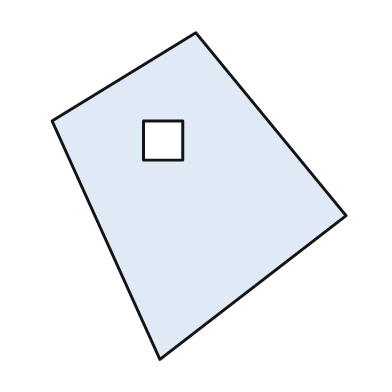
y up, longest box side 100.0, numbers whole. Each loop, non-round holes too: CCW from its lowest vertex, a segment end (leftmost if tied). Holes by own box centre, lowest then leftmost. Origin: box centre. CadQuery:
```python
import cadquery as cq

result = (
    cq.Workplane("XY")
    .moveTo(-12.0, -50.0)
    .lineTo(45.0, -6.0)
    .lineTo(-1.0, 50.0)
    .lineTo(-45.0, 23.0)
    .close()
    .moveTo(-17.0, 11.0)
    .lineTo(-5.0, 11.0)
    .lineTo(-5.0, 23.0)
    .lineTo(-17.0, 23.0)
    .close()
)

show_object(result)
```